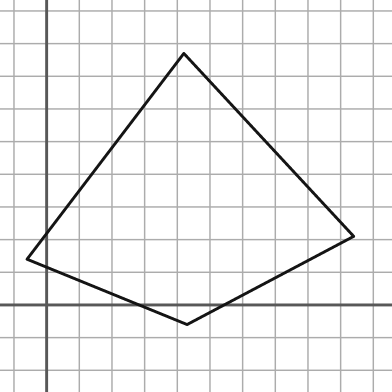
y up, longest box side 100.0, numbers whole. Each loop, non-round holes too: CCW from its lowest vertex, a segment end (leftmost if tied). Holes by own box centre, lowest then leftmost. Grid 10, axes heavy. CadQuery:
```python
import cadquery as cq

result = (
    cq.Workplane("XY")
    .moveTo(43.0, -6.0)
    .lineTo(94.0, 21.0)
    .lineTo(42.0, 77.0)
    .lineTo(-6.0, 14.0)
    .close()
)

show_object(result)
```